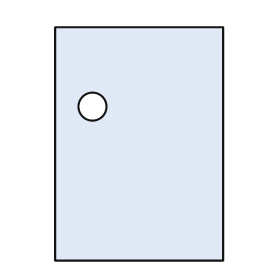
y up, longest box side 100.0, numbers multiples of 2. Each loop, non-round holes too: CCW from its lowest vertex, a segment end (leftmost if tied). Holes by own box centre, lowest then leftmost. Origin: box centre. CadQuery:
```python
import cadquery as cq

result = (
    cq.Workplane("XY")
    .moveTo(-36.0, -50.0)
    .lineTo(36.0, -50.0)
    .lineTo(36.0, 50.0)
    .lineTo(-36.0, 50.0)
    .close()
    .moveTo(-20.0, 16.0)
    .circle(6.0)
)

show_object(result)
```